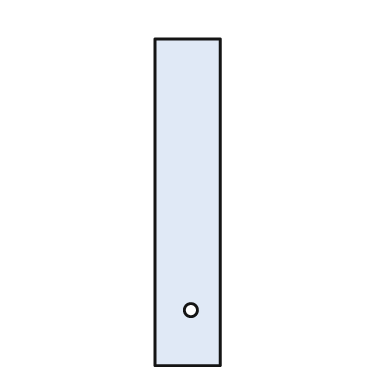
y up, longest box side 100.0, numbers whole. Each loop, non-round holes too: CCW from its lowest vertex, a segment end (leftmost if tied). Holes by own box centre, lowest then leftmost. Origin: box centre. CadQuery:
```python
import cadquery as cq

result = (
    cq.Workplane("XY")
    .moveTo(-10.0, -50.0)
    .lineTo(10.0, -50.0)
    .lineTo(10.0, 50.0)
    .lineTo(-10.0, 50.0)
    .close()
    .moveTo(1.0, -33.0)
    .circle(2.0)
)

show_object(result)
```